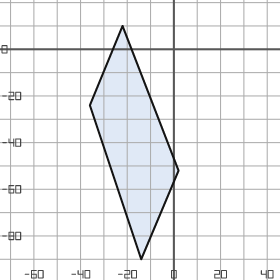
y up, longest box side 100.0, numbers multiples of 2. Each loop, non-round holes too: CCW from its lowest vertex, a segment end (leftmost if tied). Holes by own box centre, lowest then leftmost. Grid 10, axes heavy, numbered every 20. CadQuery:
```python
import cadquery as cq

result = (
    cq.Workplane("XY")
    .moveTo(-14.0, -90.0)
    .lineTo(2.0, -52.0)
    .lineTo(-22.0, 10.0)
    .lineTo(-36.0, -24.0)
    .close()
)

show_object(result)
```